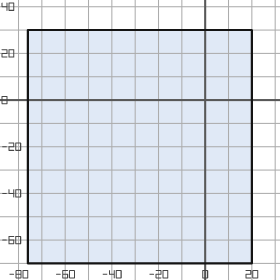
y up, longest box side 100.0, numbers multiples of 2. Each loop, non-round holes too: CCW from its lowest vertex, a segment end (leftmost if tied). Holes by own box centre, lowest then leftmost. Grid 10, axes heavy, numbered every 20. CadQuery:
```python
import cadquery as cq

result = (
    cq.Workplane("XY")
    .moveTo(-76.0, -70.0)
    .lineTo(20.0, -70.0)
    .lineTo(20.0, 30.0)
    .lineTo(-76.0, 30.0)
    .close()
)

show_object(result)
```